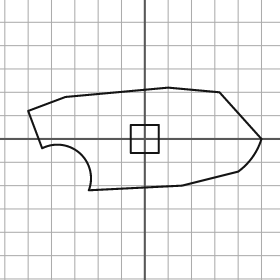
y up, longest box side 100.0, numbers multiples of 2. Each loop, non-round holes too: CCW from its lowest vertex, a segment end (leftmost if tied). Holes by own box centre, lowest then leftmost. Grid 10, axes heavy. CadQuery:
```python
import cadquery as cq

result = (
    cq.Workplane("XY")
    .moveTo(-24.0, -22.0)
    .lineTo(16.0, -20.0)
    .lineTo(40.0, -14.0)
    .threePointArc((46.0, -8.0), (50.0, 0.0))
    .lineTo(32.0, 20.0)
    .lineTo(10.0, 22.0)
    .lineTo(-34.0, 18.0)
    .lineTo(-50.0, 12.0)
    .lineTo(-44.0, -4.0)
    .threePointArc((-28.0, -6.0), (-24.0, -22.0))
    .close()
    .moveTo(-6.0, -6.0)
    .lineTo(6.0, -6.0)
    .lineTo(6.0, 6.0)
    .lineTo(-6.0, 6.0)
    .close()
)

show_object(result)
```